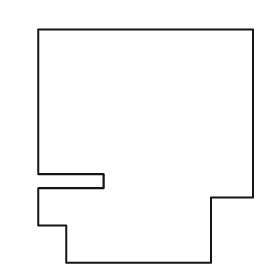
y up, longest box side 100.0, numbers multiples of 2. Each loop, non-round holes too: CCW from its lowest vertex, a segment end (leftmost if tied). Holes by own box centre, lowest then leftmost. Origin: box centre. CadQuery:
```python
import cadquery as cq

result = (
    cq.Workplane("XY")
    .moveTo(-34.0, -50.0)
    .lineTo(28.0, -50.0)
    .lineTo(28.0, -22.0)
    .lineTo(46.0, -22.0)
    .lineTo(46.0, 50.0)
    .lineTo(-46.0, 50.0)
    .lineTo(-46.0, -12.0)
    .lineTo(-18.0, -12.0)
    .lineTo(-18.0, -18.0)
    .lineTo(-46.0, -18.0)
    .lineTo(-46.0, -34.0)
    .lineTo(-34.0, -34.0)
    .close()
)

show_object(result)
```